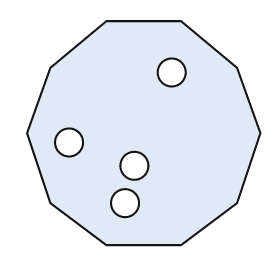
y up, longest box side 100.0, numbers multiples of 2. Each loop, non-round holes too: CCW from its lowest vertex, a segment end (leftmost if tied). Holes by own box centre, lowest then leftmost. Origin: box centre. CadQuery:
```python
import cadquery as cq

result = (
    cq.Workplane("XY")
    .moveTo(-16.0, -48.0)
    .lineTo(16.0, -48.0)
    .lineTo(40.0, -30.0)
    .lineTo(50.0, 0.0)
    .lineTo(40.0, 28.0)
    .lineTo(16.0, 48.0)
    .lineTo(-16.0, 48.0)
    .lineTo(-40.0, 28.0)
    .lineTo(-50.0, 0.0)
    .lineTo(-40.0, -30.0)
    .close()
    .moveTo(-8.0, -30.0)
    .circle(6.0)
    .moveTo(-4.0, -14.0)
    .circle(6.0)
    .moveTo(-32.0, -4.0)
    .circle(6.0)
    .moveTo(12.0, 26.0)
    .circle(6.0)
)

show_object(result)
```